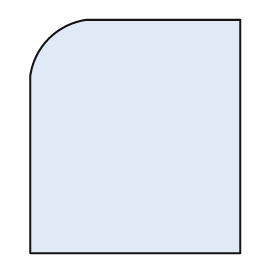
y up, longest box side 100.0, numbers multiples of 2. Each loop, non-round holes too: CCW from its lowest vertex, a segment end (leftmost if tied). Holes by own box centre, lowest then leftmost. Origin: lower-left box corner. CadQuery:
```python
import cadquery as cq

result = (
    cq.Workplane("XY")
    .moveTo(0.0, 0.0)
    .lineTo(90.0, 0.0)
    .lineTo(90.0, 100.0)
    .lineTo(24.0, 100.0)
    .threePointArc((8.0, 92.0), (0.0, 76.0))
    .close()
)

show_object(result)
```